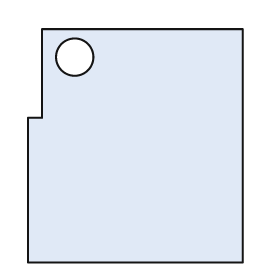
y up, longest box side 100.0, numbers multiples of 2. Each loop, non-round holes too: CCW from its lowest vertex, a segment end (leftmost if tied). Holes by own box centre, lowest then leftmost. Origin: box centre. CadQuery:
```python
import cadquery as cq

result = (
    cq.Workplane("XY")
    .moveTo(-46.0, -50.0)
    .lineTo(46.0, -50.0)
    .lineTo(46.0, 50.0)
    .lineTo(-40.0, 50.0)
    .lineTo(-40.0, 12.0)
    .lineTo(-46.0, 12.0)
    .close()
    .moveTo(-26.0, 38.0)
    .circle(8.0)
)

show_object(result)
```